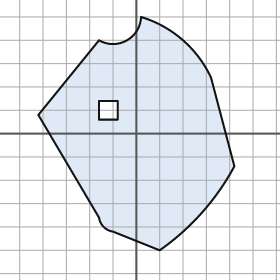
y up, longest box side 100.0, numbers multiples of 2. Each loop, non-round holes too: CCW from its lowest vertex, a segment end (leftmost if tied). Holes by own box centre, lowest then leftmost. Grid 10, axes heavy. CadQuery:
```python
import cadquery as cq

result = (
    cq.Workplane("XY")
    .moveTo(10.0, -50.0)
    .threePointArc((28.0, -34.0), (42.0, -14.0))
    .lineTo(32.0, 24.0)
    .threePointArc((20.0, 40.0), (2.0, 50.0))
    .threePointArc((-4.0, 40.0), (-16.0, 40.0))
    .lineTo(-42.0, 8.0)
    .lineTo(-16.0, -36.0)
    .threePointArc((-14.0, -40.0), (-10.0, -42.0))
    .close()
    .moveTo(-16.0, 6.0)
    .lineTo(-8.0, 6.0)
    .lineTo(-8.0, 14.0)
    .lineTo(-16.0, 14.0)
    .close()
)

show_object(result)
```